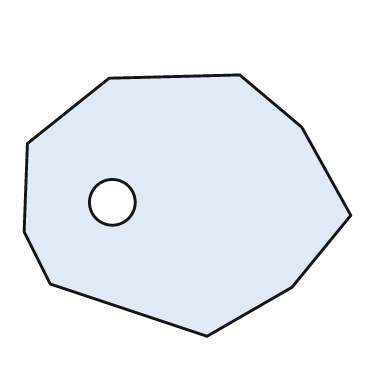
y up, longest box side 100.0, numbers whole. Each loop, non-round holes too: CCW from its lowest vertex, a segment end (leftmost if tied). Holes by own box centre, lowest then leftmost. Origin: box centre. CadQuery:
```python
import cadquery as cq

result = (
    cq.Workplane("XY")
    .moveTo(6.0, -40.0)
    .lineTo(32.0, -25.0)
    .lineTo(50.0, -3.0)
    .lineTo(35.0, 24.0)
    .lineTo(16.0, 40.0)
    .lineTo(-24.0, 39.0)
    .lineTo(-49.0, 19.0)
    .lineTo(-50.0, -8.0)
    .lineTo(-42.0, -24.0)
    .close()
    .moveTo(-23.0, 1.0)
    .circle(7.0)
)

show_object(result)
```